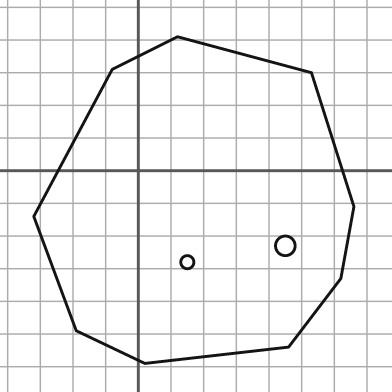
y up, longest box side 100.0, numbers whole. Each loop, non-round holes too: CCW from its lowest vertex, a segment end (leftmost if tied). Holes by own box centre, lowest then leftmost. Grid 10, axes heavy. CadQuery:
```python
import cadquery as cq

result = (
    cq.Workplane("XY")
    .moveTo(2.0, -59.0)
    .lineTo(46.0, -54.0)
    .lineTo(62.0, -33.0)
    .lineTo(66.0, -11.0)
    .lineTo(53.0, 30.0)
    .lineTo(12.0, 41.0)
    .lineTo(-8.0, 31.0)
    .lineTo(-32.0, -14.0)
    .lineTo(-19.0, -49.0)
    .close()
    .moveTo(15.0, -28.0)
    .circle(2.0)
    .moveTo(45.0, -23.0)
    .circle(3.0)
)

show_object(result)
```